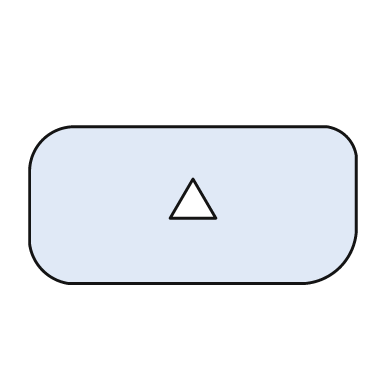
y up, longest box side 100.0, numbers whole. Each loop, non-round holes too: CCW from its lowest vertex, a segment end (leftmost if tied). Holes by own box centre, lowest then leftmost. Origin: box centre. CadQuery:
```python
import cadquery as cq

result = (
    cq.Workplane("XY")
    .moveTo(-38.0, -24.0)
    .lineTo(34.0, -24.0)
    .threePointArc((45.0, -19.0), (50.0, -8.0))
    .lineTo(50.0, 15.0)
    .threePointArc((47.0, 21.0), (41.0, 24.0))
    .lineTo(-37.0, 24.0)
    .threePointArc((-46.0, 20.0), (-50.0, 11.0))
    .lineTo(-50.0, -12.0)
    .threePointArc((-46.0, -20.0), (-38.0, -24.0))
    .close()
    .moveTo(-7.0, -4.0)
    .lineTo(7.0, -4.0)
    .lineTo(0.0, 8.0)
    .close()
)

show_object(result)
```